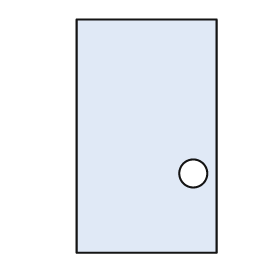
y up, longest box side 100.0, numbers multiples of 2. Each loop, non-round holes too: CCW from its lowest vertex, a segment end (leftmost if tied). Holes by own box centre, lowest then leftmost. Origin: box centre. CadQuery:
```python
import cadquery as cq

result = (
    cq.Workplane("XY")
    .moveTo(-30.0, -50.0)
    .lineTo(30.0, -50.0)
    .lineTo(30.0, 50.0)
    .lineTo(-30.0, 50.0)
    .close()
    .moveTo(20.0, -16.0)
    .circle(6.0)
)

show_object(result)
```